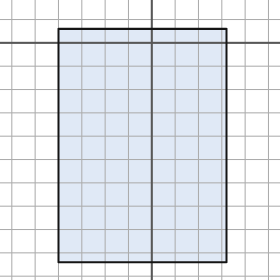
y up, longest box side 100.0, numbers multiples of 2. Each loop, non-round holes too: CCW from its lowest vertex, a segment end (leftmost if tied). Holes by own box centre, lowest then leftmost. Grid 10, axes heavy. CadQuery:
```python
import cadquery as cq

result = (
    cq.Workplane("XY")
    .moveTo(-40.0, -94.0)
    .lineTo(32.0, -94.0)
    .lineTo(32.0, 6.0)
    .lineTo(-40.0, 6.0)
    .close()
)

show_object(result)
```